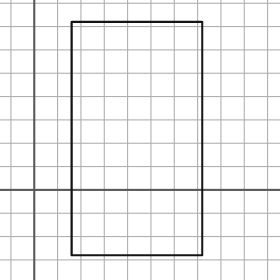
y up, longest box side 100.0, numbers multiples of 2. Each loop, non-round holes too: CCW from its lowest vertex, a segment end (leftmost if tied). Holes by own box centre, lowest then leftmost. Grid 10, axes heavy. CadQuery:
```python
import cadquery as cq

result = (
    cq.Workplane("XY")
    .moveTo(16.0, -28.0)
    .lineTo(72.0, -28.0)
    .lineTo(72.0, 72.0)
    .lineTo(16.0, 72.0)
    .close()
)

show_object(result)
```